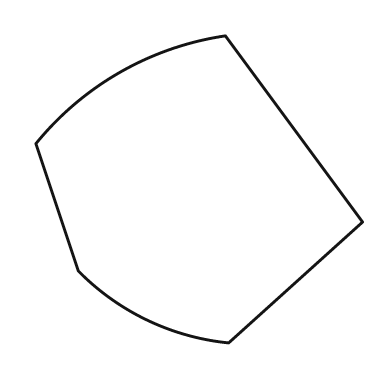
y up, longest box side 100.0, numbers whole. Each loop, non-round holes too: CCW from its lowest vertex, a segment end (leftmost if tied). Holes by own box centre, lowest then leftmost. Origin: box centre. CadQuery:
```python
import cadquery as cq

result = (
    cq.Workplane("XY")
    .moveTo(9.0, -47.0)
    .lineTo(50.0, -10.0)
    .lineTo(8.0, 47.0)
    .threePointArc((-24.0, 36.0), (-50.0, 14.0))
    .lineTo(-37.0, -25.0)
    .threePointArc((-16.0, -40.0), (9.0, -47.0))
    .close()
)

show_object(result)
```